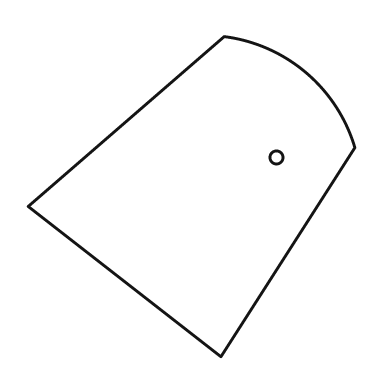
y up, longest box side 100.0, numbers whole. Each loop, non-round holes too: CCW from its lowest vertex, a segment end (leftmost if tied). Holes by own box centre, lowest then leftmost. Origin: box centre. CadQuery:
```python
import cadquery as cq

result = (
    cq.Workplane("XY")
    .moveTo(9.0, -49.0)
    .lineTo(50.0, 15.0)
    .threePointArc((35.0, 38.0), (10.0, 49.0))
    .lineTo(-50.0, -3.0)
    .close()
    .moveTo(26.0, 12.0)
    .circle(2.0)
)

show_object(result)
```